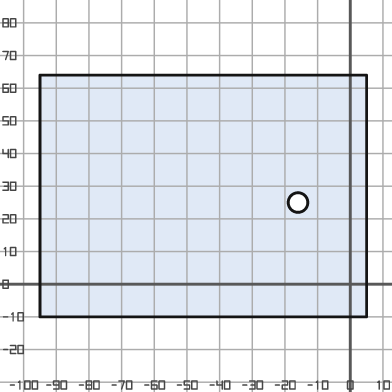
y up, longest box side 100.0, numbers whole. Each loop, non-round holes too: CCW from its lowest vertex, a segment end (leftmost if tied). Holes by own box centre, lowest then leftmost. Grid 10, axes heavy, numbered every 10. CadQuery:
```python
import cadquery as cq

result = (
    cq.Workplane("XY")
    .moveTo(-95.0, -10.0)
    .lineTo(5.0, -10.0)
    .lineTo(5.0, 64.0)
    .lineTo(-95.0, 64.0)
    .close()
    .moveTo(-16.0, 25.0)
    .circle(3.0)
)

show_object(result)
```